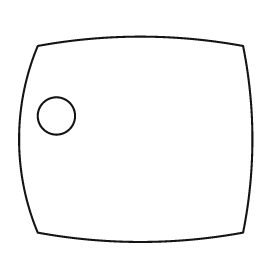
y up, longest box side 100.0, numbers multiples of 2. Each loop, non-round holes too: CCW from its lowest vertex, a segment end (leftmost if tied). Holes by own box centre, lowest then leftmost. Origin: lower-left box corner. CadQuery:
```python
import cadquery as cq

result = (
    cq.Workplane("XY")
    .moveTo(8.0, 4.0)
    .threePointArc((52.0, 0.0), (96.0, 4.0))
    .threePointArc((100.0, 44.0), (96.0, 84.0))
    .threePointArc((52.0, 88.0), (8.0, 84.0))
    .threePointArc((0.0, 44.0), (8.0, 4.0))
    .close()
    .moveTo(16.0, 54.0)
    .circle(8.0)
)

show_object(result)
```